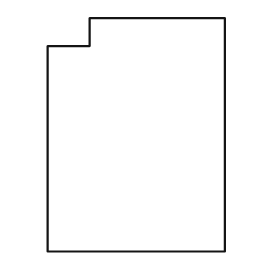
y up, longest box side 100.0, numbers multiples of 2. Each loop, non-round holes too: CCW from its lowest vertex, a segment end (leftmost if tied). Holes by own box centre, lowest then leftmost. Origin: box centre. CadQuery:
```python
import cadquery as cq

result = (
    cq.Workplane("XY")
    .moveTo(-38.0, -50.0)
    .lineTo(38.0, -50.0)
    .lineTo(38.0, 50.0)
    .lineTo(-20.0, 50.0)
    .lineTo(-20.0, 38.0)
    .lineTo(-38.0, 38.0)
    .close()
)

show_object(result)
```